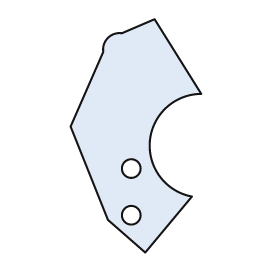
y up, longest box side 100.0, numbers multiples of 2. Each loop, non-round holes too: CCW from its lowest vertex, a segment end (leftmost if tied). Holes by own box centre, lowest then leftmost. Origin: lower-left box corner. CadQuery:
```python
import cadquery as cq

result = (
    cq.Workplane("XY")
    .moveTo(32.0, 0.0)
    .lineTo(52.0, 24.0)
    .threePointArc((34.0, 48.0), (56.0, 68.0))
    .lineTo(36.0, 100.0)
    .lineTo(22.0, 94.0)
    .threePointArc((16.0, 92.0), (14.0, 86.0))
    .lineTo(0.0, 54.0)
    .lineTo(16.0, 14.0)
    .close()
    .moveTo(26.0, 16.0)
    .circle(4.0)
    .moveTo(26.0, 36.0)
    .circle(4.0)
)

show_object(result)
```